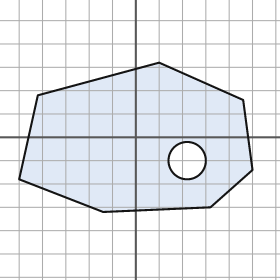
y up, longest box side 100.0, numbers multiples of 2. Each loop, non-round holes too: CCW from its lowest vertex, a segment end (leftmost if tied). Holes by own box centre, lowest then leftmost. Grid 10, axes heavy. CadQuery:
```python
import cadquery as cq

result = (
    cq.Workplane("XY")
    .moveTo(-14.0, -32.0)
    .lineTo(32.0, -30.0)
    .lineTo(50.0, -14.0)
    .lineTo(46.0, 16.0)
    .lineTo(10.0, 32.0)
    .lineTo(-42.0, 18.0)
    .lineTo(-50.0, -18.0)
    .close()
    .moveTo(22.0, -10.0)
    .circle(8.0)
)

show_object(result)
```